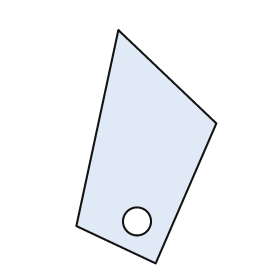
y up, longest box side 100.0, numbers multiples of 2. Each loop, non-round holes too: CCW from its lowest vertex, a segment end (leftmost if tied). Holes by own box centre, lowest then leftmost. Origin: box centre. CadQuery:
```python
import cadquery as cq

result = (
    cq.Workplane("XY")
    .moveTo(4.0, -50.0)
    .lineTo(30.0, 10.0)
    .lineTo(-12.0, 50.0)
    .lineTo(-30.0, -34.0)
    .close()
    .moveTo(-4.0, -32.0)
    .circle(6.0)
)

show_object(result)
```